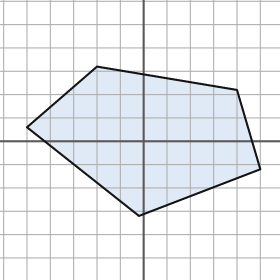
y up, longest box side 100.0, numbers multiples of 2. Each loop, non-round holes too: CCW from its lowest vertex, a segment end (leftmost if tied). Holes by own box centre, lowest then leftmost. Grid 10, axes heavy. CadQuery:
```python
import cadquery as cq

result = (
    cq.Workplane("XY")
    .moveTo(-2.0, -32.0)
    .lineTo(50.0, -12.0)
    .lineTo(40.0, 22.0)
    .lineTo(-20.0, 32.0)
    .lineTo(-50.0, 6.0)
    .close()
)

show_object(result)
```